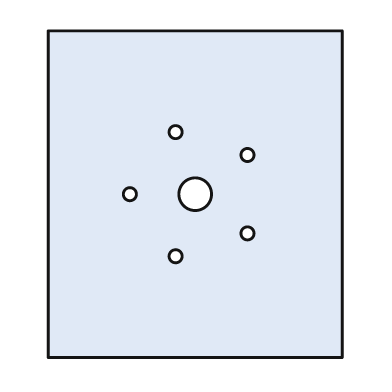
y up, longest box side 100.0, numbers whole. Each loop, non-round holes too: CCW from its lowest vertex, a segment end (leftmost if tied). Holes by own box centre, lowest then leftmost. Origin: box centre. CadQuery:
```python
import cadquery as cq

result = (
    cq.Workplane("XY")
    .moveTo(-45.0, -50.0)
    .lineTo(45.0, -50.0)
    .lineTo(45.0, 50.0)
    .lineTo(-45.0, 50.0)
    .close()
    .moveTo(-6.0, -19.0)
    .circle(2.0)
    .moveTo(16.0, -12.0)
    .circle(2.0)
    .moveTo(-20.0, 0.0)
    .circle(2.0)
    .moveTo(0.0, 0.0)
    .circle(5.0)
    .moveTo(16.0, 12.0)
    .circle(2.0)
    .moveTo(-6.0, 19.0)
    .circle(2.0)
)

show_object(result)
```